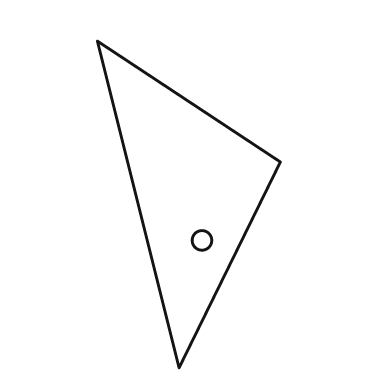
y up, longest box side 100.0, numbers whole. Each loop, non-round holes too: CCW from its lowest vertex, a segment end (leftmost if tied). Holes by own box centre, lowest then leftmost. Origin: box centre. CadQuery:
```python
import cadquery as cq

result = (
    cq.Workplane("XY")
    .moveTo(-3.0, -50.0)
    .lineTo(28.0, 13.0)
    .lineTo(-28.0, 50.0)
    .close()
    .moveTo(4.0, -11.0)
    .circle(3.0)
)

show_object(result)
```